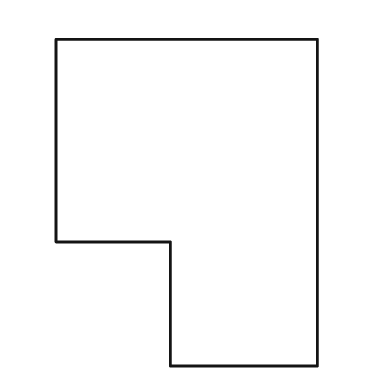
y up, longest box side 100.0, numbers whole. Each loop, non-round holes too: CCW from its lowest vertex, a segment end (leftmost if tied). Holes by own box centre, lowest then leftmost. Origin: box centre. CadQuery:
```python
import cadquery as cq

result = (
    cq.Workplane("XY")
    .moveTo(-5.0, -50.0)
    .lineTo(40.0, -50.0)
    .lineTo(40.0, 50.0)
    .lineTo(-40.0, 50.0)
    .lineTo(-40.0, -12.0)
    .lineTo(-5.0, -12.0)
    .close()
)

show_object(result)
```